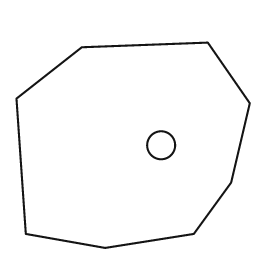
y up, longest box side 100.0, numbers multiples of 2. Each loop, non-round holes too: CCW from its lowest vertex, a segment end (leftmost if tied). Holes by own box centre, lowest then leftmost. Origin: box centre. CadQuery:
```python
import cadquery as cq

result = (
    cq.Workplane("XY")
    .moveTo(-12.0, -44.0)
    .lineTo(26.0, -38.0)
    .lineTo(42.0, -16.0)
    .lineTo(50.0, 18.0)
    .lineTo(32.0, 44.0)
    .lineTo(-22.0, 42.0)
    .lineTo(-50.0, 20.0)
    .lineTo(-46.0, -38.0)
    .close()
    .moveTo(12.0, 0.0)
    .circle(6.0)
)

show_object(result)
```